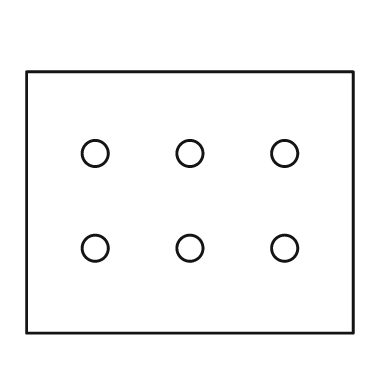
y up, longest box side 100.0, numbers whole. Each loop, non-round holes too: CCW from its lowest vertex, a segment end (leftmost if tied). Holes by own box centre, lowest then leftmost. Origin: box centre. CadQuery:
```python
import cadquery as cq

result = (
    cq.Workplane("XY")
    .moveTo(-50.0, -40.0)
    .lineTo(50.0, -40.0)
    .lineTo(50.0, 40.0)
    .lineTo(-50.0, 40.0)
    .close()
    .moveTo(-29.0, -14.0)
    .circle(4.0)
    .moveTo(0.0, -14.0)
    .circle(4.0)
    .moveTo(29.0, -14.0)
    .circle(4.0)
    .moveTo(-29.0, 15.0)
    .circle(4.0)
    .moveTo(0.0, 15.0)
    .circle(4.0)
    .moveTo(29.0, 15.0)
    .circle(4.0)
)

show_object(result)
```